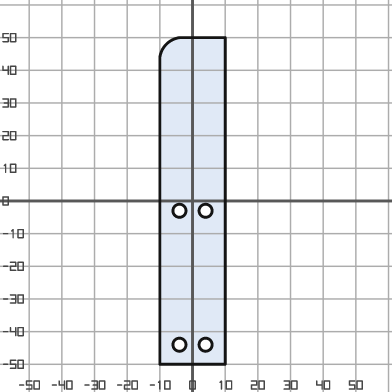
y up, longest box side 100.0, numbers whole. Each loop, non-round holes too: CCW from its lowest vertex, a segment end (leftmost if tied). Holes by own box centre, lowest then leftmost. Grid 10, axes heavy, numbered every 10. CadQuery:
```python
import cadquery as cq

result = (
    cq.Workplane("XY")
    .moveTo(-10.0, -50.0)
    .lineTo(10.0, -50.0)
    .lineTo(10.0, 50.0)
    .lineTo(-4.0, 50.0)
    .threePointArc((-8.0, 48.0), (-10.0, 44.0))
    .close()
    .moveTo(-4.0, -44.0)
    .circle(2.0)
    .moveTo(4.0, -44.0)
    .circle(2.0)
    .moveTo(-4.0, -3.0)
    .circle(2.0)
    .moveTo(4.0, -3.0)
    .circle(2.0)
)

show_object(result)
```